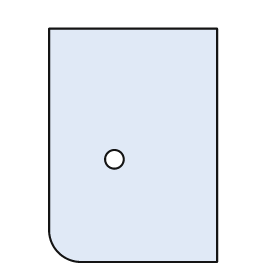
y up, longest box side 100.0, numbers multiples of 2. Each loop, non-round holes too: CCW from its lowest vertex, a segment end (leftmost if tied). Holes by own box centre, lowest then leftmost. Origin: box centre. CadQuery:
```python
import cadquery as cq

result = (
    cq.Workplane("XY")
    .moveTo(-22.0, -50.0)
    .lineTo(36.0, -50.0)
    .lineTo(36.0, 50.0)
    .lineTo(-36.0, 50.0)
    .lineTo(-36.0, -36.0)
    .threePointArc((-32.0, -46.0), (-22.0, -50.0))
    .close()
    .moveTo(-8.0, -6.0)
    .circle(4.0)
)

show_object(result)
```